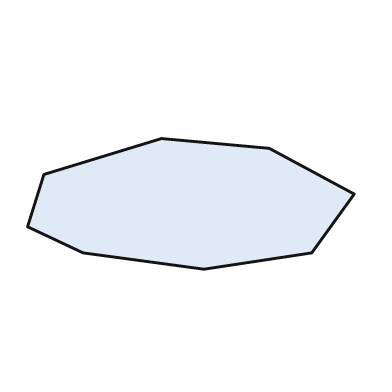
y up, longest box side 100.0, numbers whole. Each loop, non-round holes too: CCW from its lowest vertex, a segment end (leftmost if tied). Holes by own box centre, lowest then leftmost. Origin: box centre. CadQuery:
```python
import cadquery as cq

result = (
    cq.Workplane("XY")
    .moveTo(4.0, -20.0)
    .lineTo(37.0, -15.0)
    .lineTo(50.0, 3.0)
    .lineTo(24.0, 17.0)
    .lineTo(-9.0, 20.0)
    .lineTo(-45.0, 9.0)
    .lineTo(-50.0, -7.0)
    .lineTo(-33.0, -15.0)
    .close()
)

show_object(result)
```